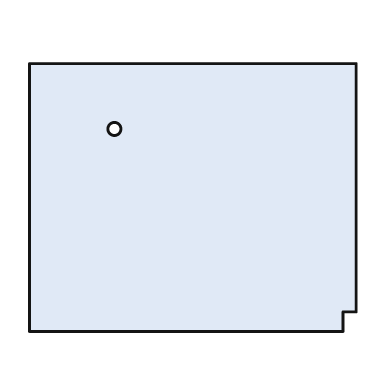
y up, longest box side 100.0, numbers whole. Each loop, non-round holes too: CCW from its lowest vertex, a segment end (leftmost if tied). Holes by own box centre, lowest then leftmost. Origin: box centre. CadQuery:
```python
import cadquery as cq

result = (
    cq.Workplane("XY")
    .moveTo(-50.0, -41.0)
    .lineTo(46.0, -41.0)
    .lineTo(46.0, -35.0)
    .lineTo(50.0, -35.0)
    .lineTo(50.0, 41.0)
    .lineTo(-50.0, 41.0)
    .close()
    .moveTo(-24.0, 21.0)
    .circle(2.0)
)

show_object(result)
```